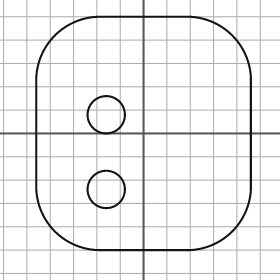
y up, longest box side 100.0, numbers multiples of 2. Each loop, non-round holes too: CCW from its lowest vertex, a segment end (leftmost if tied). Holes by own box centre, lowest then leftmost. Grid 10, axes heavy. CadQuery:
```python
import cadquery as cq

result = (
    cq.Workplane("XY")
    .moveTo(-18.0, -50.0)
    .lineTo(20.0, -50.0)
    .threePointArc((38.0, -42.0), (46.0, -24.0))
    .lineTo(46.0, 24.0)
    .threePointArc((38.0, 42.0), (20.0, 50.0))
    .lineTo(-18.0, 50.0)
    .threePointArc((-38.0, 42.0), (-46.0, 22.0))
    .lineTo(-46.0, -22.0)
    .threePointArc((-38.0, -42.0), (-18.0, -50.0))
    .close()
    .moveTo(-16.0, -24.0)
    .circle(8.0)
    .moveTo(-16.0, 8.0)
    .circle(8.0)
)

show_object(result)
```